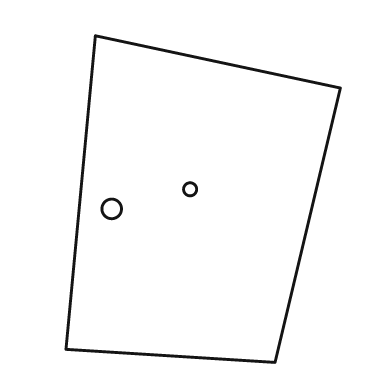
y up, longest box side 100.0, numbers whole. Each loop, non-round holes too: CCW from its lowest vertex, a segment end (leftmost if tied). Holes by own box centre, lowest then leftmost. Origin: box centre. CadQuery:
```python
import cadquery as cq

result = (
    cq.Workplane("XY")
    .moveTo(22.0, -50.0)
    .lineTo(42.0, 34.0)
    .lineTo(-33.0, 50.0)
    .lineTo(-42.0, -46.0)
    .close()
    .moveTo(-28.0, -3.0)
    .circle(3.0)
    .moveTo(-4.0, 3.0)
    .circle(2.0)
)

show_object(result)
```